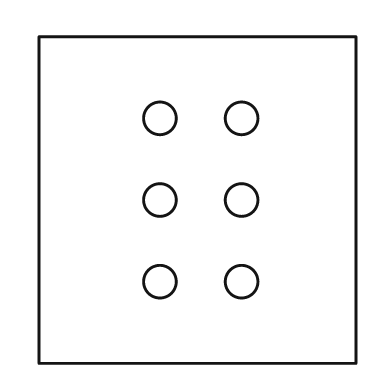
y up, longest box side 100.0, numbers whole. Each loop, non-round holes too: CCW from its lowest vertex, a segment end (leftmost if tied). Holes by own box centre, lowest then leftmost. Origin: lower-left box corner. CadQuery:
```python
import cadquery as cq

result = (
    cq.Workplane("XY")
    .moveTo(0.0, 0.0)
    .lineTo(97.0, 0.0)
    .lineTo(97.0, 100.0)
    .lineTo(0.0, 100.0)
    .close()
    .moveTo(37.0, 25.0)
    .circle(5.0)
    .moveTo(62.0, 25.0)
    .circle(5.0)
    .moveTo(37.0, 50.0)
    .circle(5.0)
    .moveTo(62.0, 50.0)
    .circle(5.0)
    .moveTo(37.0, 75.0)
    .circle(5.0)
    .moveTo(62.0, 75.0)
    .circle(5.0)
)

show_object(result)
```